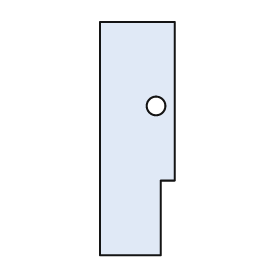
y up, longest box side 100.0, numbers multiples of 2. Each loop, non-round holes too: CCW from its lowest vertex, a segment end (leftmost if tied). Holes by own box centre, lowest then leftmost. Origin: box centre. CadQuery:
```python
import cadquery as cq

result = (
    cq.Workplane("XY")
    .moveTo(-16.0, -50.0)
    .lineTo(10.0, -50.0)
    .lineTo(10.0, -18.0)
    .lineTo(16.0, -18.0)
    .lineTo(16.0, 50.0)
    .lineTo(-16.0, 50.0)
    .close()
    .moveTo(8.0, 14.0)
    .circle(4.0)
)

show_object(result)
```